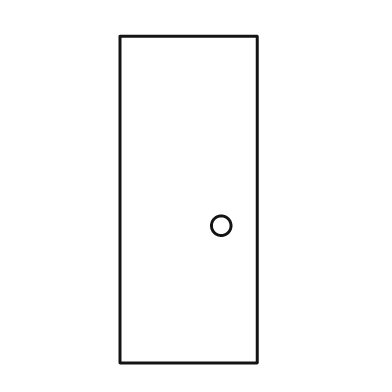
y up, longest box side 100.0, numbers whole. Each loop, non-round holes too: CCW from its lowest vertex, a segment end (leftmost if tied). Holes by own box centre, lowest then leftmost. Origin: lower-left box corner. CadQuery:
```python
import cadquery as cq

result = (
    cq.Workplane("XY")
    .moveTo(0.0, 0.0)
    .lineTo(42.0, 0.0)
    .lineTo(42.0, 100.0)
    .lineTo(0.0, 100.0)
    .close()
    .moveTo(31.0, 42.0)
    .circle(3.0)
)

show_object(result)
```